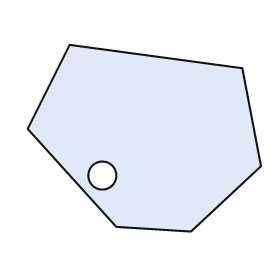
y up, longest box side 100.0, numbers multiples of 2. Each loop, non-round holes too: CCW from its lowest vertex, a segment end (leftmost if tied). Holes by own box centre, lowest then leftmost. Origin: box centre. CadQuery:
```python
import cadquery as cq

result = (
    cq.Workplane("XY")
    .moveTo(20.0, -40.0)
    .lineTo(50.0, -12.0)
    .lineTo(42.0, 30.0)
    .lineTo(-32.0, 40.0)
    .lineTo(-50.0, 4.0)
    .lineTo(-12.0, -38.0)
    .close()
    .moveTo(-18.0, -16.0)
    .circle(6.0)
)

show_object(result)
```